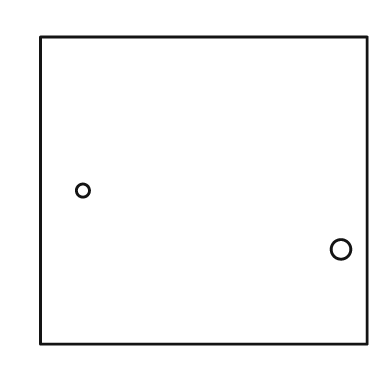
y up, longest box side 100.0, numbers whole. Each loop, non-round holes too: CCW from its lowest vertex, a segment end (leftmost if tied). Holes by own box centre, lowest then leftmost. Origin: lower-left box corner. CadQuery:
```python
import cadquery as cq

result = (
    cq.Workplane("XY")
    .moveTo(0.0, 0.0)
    .lineTo(100.0, 0.0)
    .lineTo(100.0, 94.0)
    .lineTo(0.0, 94.0)
    .close()
    .moveTo(92.0, 29.0)
    .circle(3.0)
    .moveTo(13.0, 47.0)
    .circle(2.0)
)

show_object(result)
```